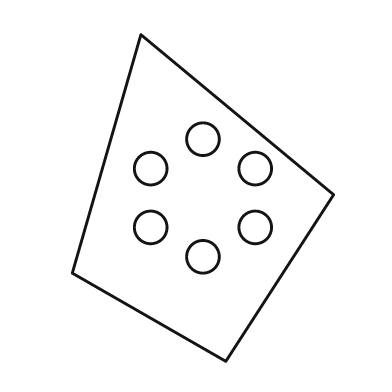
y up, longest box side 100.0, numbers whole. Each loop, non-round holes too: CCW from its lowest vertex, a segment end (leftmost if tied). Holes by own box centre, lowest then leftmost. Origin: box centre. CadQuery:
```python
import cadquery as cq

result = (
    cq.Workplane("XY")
    .moveTo(7.0, -50.0)
    .lineTo(40.0, 1.0)
    .lineTo(-19.0, 50.0)
    .lineTo(-40.0, -23.0)
    .close()
    .moveTo(0.0, -18.0)
    .circle(5.0)
    .moveTo(-16.0, -9.0)
    .circle(5.0)
    .moveTo(16.0, -9.0)
    .circle(5.0)
    .moveTo(-16.0, 9.0)
    .circle(5.0)
    .moveTo(16.0, 9.0)
    .circle(5.0)
    .moveTo(0.0, 18.0)
    .circle(5.0)
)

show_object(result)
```